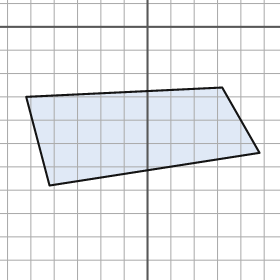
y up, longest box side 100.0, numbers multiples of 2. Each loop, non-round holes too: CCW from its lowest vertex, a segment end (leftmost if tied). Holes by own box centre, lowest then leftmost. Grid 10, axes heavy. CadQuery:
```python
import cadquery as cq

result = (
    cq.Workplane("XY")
    .moveTo(-42.0, -68.0)
    .lineTo(48.0, -54.0)
    .lineTo(32.0, -26.0)
    .lineTo(-52.0, -30.0)
    .close()
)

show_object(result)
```